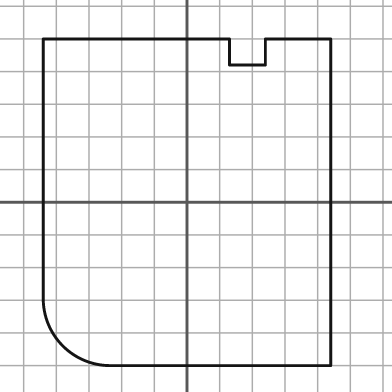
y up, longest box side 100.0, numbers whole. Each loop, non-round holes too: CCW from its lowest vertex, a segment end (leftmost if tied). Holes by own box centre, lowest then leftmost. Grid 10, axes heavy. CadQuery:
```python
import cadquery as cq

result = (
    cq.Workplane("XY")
    .moveTo(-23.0, -50.0)
    .lineTo(44.0, -50.0)
    .lineTo(44.0, 50.0)
    .lineTo(24.0, 50.0)
    .lineTo(24.0, 42.0)
    .lineTo(13.0, 42.0)
    .lineTo(13.0, 50.0)
    .lineTo(-44.0, 50.0)
    .lineTo(-44.0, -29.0)
    .threePointArc((-38.0, -44.0), (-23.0, -50.0))
    .close()
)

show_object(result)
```